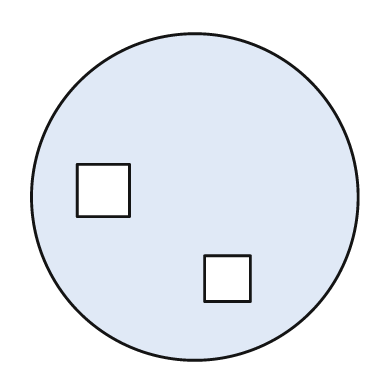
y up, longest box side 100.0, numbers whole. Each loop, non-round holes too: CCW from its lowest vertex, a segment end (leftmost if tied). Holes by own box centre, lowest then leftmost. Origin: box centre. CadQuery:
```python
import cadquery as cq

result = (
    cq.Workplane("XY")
    .moveTo(0.0, 0.0)
    .circle(50.0)
    .moveTo(3.0, -32.0)
    .lineTo(17.0, -32.0)
    .lineTo(17.0, -18.0)
    .lineTo(3.0, -18.0)
    .close()
    .moveTo(-36.0, -6.0)
    .lineTo(-20.0, -6.0)
    .lineTo(-20.0, 10.0)
    .lineTo(-36.0, 10.0)
    .close()
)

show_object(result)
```